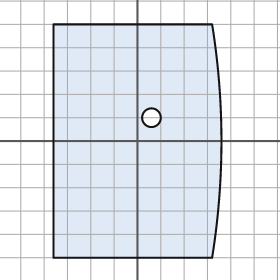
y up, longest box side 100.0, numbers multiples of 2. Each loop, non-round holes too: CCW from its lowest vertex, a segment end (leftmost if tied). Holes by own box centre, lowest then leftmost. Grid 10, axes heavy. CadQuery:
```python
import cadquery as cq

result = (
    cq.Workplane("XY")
    .moveTo(-36.0, -50.0)
    .lineTo(32.0, -50.0)
    .threePointArc((36.0, 0.0), (32.0, 50.0))
    .lineTo(-36.0, 50.0)
    .close()
    .moveTo(6.0, 10.0)
    .circle(4.0)
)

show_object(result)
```